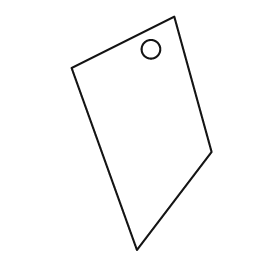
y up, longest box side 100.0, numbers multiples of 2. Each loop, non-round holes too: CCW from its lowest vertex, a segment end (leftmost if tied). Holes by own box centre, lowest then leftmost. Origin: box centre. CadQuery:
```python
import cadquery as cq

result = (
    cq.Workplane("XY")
    .moveTo(-2.0, -50.0)
    .lineTo(30.0, -8.0)
    .lineTo(14.0, 50.0)
    .lineTo(-30.0, 28.0)
    .close()
    .moveTo(4.0, 36.0)
    .circle(4.0)
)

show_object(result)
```